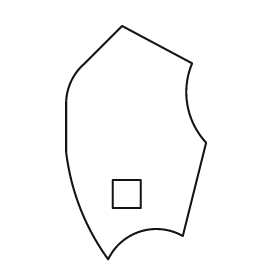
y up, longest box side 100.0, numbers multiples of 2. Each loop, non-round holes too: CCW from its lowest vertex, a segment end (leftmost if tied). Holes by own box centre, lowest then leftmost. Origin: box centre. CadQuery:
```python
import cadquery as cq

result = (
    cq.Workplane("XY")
    .moveTo(-12.0, -50.0)
    .threePointArc((2.0, -38.0), (20.0, -40.0))
    .lineTo(30.0, 0.0)
    .threePointArc((22.0, 16.0), (24.0, 34.0))
    .lineTo(-6.0, 50.0)
    .lineTo(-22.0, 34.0)
    .threePointArc((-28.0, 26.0), (-30.0, 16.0))
    .lineTo(-30.0, -4.0)
    .threePointArc((-24.0, -28.0), (-12.0, -50.0))
    .close()
    .moveTo(-10.0, -28.0)
    .lineTo(2.0, -28.0)
    .lineTo(2.0, -16.0)
    .lineTo(-10.0, -16.0)
    .close()
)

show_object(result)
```